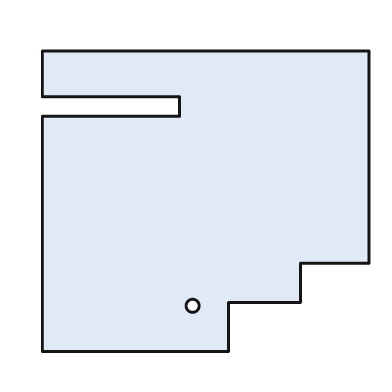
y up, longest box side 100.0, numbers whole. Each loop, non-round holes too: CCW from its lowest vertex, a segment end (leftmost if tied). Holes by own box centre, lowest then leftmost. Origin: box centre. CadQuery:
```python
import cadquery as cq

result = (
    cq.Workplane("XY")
    .moveTo(-50.0, -46.0)
    .lineTo(7.0, -46.0)
    .lineTo(7.0, -31.0)
    .lineTo(29.0, -31.0)
    .lineTo(29.0, -19.0)
    .lineTo(50.0, -19.0)
    .lineTo(50.0, 46.0)
    .lineTo(-50.0, 46.0)
    .lineTo(-50.0, 32.0)
    .lineTo(-8.0, 32.0)
    .lineTo(-8.0, 26.0)
    .lineTo(-50.0, 26.0)
    .close()
    .moveTo(-4.0, -32.0)
    .circle(2.0)
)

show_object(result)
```